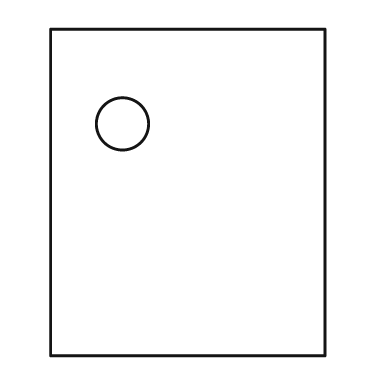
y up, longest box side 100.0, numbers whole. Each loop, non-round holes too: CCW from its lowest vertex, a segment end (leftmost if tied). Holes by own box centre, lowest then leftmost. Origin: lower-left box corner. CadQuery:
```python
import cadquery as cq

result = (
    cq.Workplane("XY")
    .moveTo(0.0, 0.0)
    .lineTo(84.0, 0.0)
    .lineTo(84.0, 100.0)
    .lineTo(0.0, 100.0)
    .close()
    .moveTo(22.0, 71.0)
    .circle(8.0)
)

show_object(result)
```